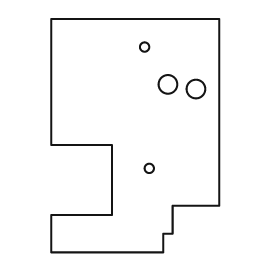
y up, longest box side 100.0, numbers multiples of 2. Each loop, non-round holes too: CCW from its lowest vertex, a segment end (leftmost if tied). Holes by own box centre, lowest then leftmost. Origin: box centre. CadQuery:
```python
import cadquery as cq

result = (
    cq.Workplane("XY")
    .moveTo(-36.0, -50.0)
    .lineTo(12.0, -50.0)
    .lineTo(12.0, -42.0)
    .lineTo(16.0, -42.0)
    .lineTo(16.0, -30.0)
    .lineTo(36.0, -30.0)
    .lineTo(36.0, 50.0)
    .lineTo(-36.0, 50.0)
    .lineTo(-36.0, -4.0)
    .lineTo(-10.0, -4.0)
    .lineTo(-10.0, -34.0)
    .lineTo(-36.0, -34.0)
    .close()
    .moveTo(6.0, -14.0)
    .circle(2.0)
    .moveTo(26.0, 20.0)
    .circle(4.0)
    .moveTo(14.0, 22.0)
    .circle(4.0)
    .moveTo(4.0, 38.0)
    .circle(2.0)
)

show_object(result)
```